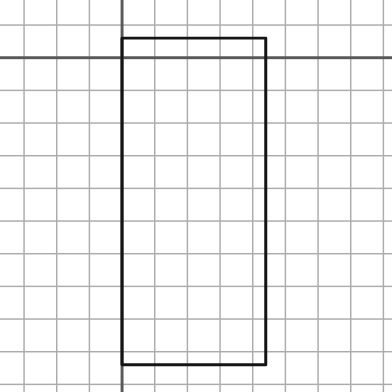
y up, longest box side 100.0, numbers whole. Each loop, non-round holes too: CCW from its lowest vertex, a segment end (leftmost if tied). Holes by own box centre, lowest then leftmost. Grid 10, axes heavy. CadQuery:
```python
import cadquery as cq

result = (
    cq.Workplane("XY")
    .moveTo(0.0, -94.0)
    .lineTo(44.0, -94.0)
    .lineTo(44.0, 6.0)
    .lineTo(0.0, 6.0)
    .close()
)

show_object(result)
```